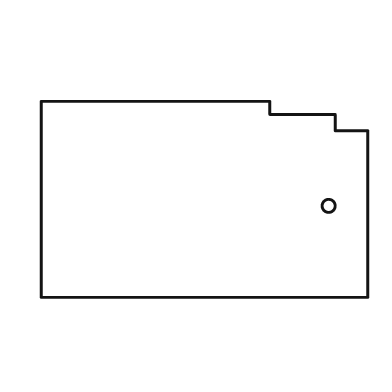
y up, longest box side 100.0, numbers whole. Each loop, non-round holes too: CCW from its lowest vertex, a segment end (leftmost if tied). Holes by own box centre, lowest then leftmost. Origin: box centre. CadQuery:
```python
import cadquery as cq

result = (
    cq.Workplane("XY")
    .moveTo(-50.0, -30.0)
    .lineTo(50.0, -30.0)
    .lineTo(50.0, 21.0)
    .lineTo(40.0, 21.0)
    .lineTo(40.0, 26.0)
    .lineTo(20.0, 26.0)
    .lineTo(20.0, 30.0)
    .lineTo(-50.0, 30.0)
    .close()
    .moveTo(38.0, -2.0)
    .circle(2.0)
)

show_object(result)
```